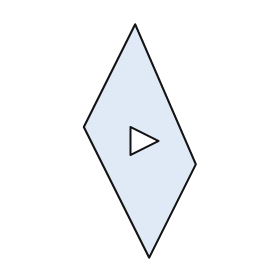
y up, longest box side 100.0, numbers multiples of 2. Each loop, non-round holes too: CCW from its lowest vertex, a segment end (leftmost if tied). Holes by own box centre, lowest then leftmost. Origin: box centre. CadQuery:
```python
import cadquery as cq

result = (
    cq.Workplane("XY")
    .moveTo(4.0, -50.0)
    .lineTo(24.0, -10.0)
    .lineTo(-2.0, 50.0)
    .lineTo(-24.0, 6.0)
    .close()
    .moveTo(-4.0, -6.0)
    .lineTo(8.0, 0.0)
    .lineTo(-4.0, 6.0)
    .close()
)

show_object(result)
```